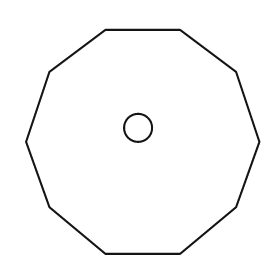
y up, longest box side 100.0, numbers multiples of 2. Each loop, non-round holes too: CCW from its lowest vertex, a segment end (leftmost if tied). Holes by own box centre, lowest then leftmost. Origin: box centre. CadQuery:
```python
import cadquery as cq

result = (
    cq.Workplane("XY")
    .moveTo(-16.0, -48.0)
    .lineTo(16.0, -48.0)
    .lineTo(40.0, -28.0)
    .lineTo(50.0, 0.0)
    .lineTo(40.0, 30.0)
    .lineTo(16.0, 48.0)
    .lineTo(-16.0, 48.0)
    .lineTo(-40.0, 30.0)
    .lineTo(-50.0, 0.0)
    .lineTo(-40.0, -28.0)
    .close()
    .moveTo(-2.0, 6.0)
    .circle(6.0)
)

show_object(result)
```